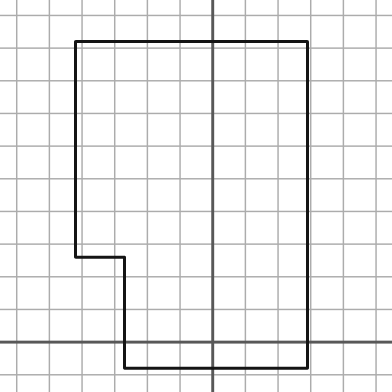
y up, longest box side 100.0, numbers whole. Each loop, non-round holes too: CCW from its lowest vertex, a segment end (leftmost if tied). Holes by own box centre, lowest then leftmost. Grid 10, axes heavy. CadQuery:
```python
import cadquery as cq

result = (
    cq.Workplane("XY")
    .moveTo(-27.0, -8.0)
    .lineTo(29.0, -8.0)
    .lineTo(29.0, 92.0)
    .lineTo(-42.0, 92.0)
    .lineTo(-42.0, 26.0)
    .lineTo(-27.0, 26.0)
    .close()
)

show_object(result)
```